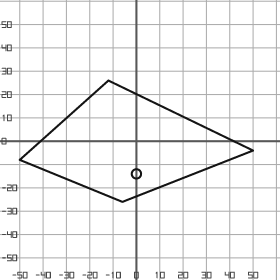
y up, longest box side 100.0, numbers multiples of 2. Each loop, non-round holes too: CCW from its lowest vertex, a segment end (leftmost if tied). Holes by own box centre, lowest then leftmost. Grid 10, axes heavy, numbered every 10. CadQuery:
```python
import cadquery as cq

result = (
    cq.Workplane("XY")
    .moveTo(-6.0, -26.0)
    .lineTo(50.0, -4.0)
    .lineTo(-12.0, 26.0)
    .lineTo(-50.0, -8.0)
    .close()
    .moveTo(0.0, -14.0)
    .circle(2.0)
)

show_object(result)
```